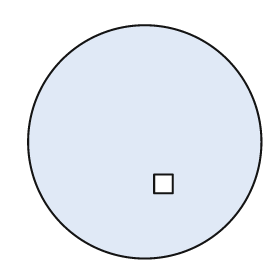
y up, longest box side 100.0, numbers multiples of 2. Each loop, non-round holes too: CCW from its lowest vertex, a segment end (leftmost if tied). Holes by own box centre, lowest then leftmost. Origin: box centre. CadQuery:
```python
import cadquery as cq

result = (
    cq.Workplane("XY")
    .moveTo(0.0, 0.0)
    .circle(50.0)
    .moveTo(4.0, -22.0)
    .lineTo(12.0, -22.0)
    .lineTo(12.0, -14.0)
    .lineTo(4.0, -14.0)
    .close()
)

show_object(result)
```